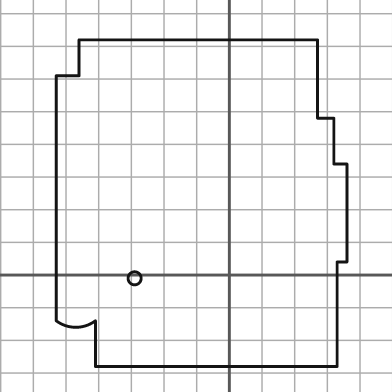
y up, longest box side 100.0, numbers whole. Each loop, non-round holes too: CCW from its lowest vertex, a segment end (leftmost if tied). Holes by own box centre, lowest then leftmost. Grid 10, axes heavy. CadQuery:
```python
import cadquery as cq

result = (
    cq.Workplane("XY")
    .moveTo(-41.0, -28.0)
    .lineTo(33.0, -28.0)
    .lineTo(33.0, 4.0)
    .lineTo(36.0, 4.0)
    .lineTo(36.0, 34.0)
    .lineTo(32.0, 34.0)
    .lineTo(32.0, 48.0)
    .lineTo(27.0, 48.0)
    .lineTo(27.0, 72.0)
    .lineTo(-46.0, 72.0)
    .lineTo(-46.0, 61.0)
    .lineTo(-53.0, 61.0)
    .lineTo(-53.0, -14.0)
    .threePointArc((-47.0, -16.0), (-41.0, -14.0))
    .close()
    .moveTo(-29.0, -1.0)
    .circle(2.0)
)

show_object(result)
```